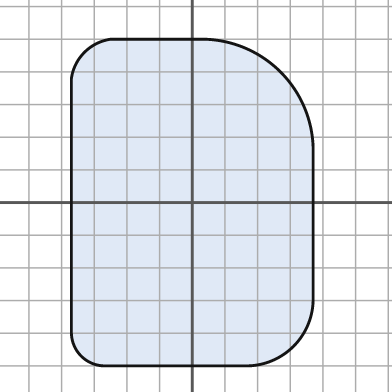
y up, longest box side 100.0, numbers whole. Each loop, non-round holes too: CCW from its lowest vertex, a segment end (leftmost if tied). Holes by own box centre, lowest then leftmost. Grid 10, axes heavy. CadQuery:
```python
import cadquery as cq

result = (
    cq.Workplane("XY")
    .moveTo(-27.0, -50.0)
    .lineTo(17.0, -50.0)
    .threePointArc((31.0, -44.0), (37.0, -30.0))
    .lineTo(37.0, 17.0)
    .threePointArc((27.0, 40.0), (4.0, 50.0))
    .lineTo(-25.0, 50.0)
    .threePointArc((-33.0, 46.0), (-37.0, 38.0))
    .lineTo(-37.0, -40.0)
    .threePointArc((-34.0, -47.0), (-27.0, -50.0))
    .close()
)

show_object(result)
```